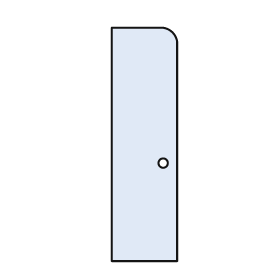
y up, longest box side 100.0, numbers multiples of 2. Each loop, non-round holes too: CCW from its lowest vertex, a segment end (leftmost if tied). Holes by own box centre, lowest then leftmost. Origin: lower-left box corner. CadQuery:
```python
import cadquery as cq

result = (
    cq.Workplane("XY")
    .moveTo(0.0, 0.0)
    .lineTo(28.0, 0.0)
    .lineTo(28.0, 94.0)
    .threePointArc((26.0, 98.0), (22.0, 100.0))
    .lineTo(0.0, 100.0)
    .close()
    .moveTo(22.0, 42.0)
    .circle(2.0)
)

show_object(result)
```